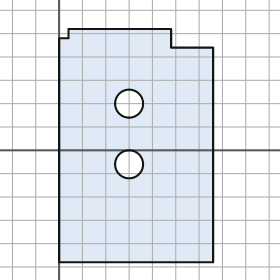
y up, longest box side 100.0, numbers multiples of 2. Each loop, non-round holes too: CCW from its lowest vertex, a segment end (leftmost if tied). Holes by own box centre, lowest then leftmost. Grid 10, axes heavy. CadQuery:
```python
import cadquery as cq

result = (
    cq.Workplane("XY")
    .moveTo(0.0, -48.0)
    .lineTo(66.0, -48.0)
    .lineTo(66.0, 44.0)
    .lineTo(48.0, 44.0)
    .lineTo(48.0, 52.0)
    .lineTo(4.0, 52.0)
    .lineTo(4.0, 48.0)
    .lineTo(0.0, 48.0)
    .close()
    .moveTo(30.0, -6.0)
    .circle(6.0)
    .moveTo(30.0, 20.0)
    .circle(6.0)
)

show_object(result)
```